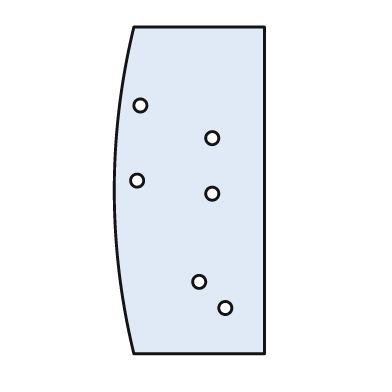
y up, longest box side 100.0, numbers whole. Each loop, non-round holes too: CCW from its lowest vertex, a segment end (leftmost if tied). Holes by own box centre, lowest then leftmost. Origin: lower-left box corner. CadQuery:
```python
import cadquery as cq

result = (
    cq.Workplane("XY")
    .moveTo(6.0, 0.0)
    .lineTo(46.0, 0.0)
    .lineTo(46.0, 100.0)
    .lineTo(6.0, 100.0)
    .threePointArc((0.0, 50.0), (6.0, 0.0))
    .close()
    .moveTo(34.0, 14.0)
    .circle(2.0)
    .moveTo(26.0, 22.0)
    .circle(2.0)
    .moveTo(30.0, 49.0)
    .circle(2.0)
    .moveTo(7.0, 53.0)
    .circle(2.0)
    .moveTo(30.0, 66.0)
    .circle(2.0)
    .moveTo(8.0, 76.0)
    .circle(2.0)
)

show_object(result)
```